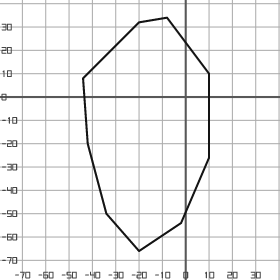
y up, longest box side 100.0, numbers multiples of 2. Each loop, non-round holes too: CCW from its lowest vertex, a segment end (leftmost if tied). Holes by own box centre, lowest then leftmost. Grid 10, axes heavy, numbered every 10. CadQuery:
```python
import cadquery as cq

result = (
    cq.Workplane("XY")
    .moveTo(-20.0, -66.0)
    .lineTo(-2.0, -54.0)
    .lineTo(10.0, -26.0)
    .lineTo(10.0, 10.0)
    .lineTo(-8.0, 34.0)
    .lineTo(-20.0, 32.0)
    .lineTo(-44.0, 8.0)
    .lineTo(-42.0, -20.0)
    .lineTo(-34.0, -50.0)
    .close()
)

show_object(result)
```